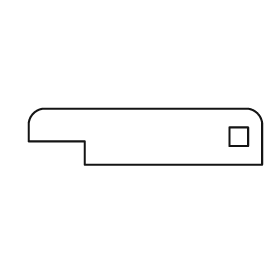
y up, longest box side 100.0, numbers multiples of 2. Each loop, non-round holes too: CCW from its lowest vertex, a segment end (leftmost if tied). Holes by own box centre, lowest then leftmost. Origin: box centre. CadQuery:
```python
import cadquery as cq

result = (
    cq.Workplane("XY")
    .moveTo(-26.0, -12.0)
    .lineTo(50.0, -12.0)
    .lineTo(50.0, 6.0)
    .threePointArc((48.0, 10.0), (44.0, 12.0))
    .lineTo(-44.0, 12.0)
    .threePointArc((-48.0, 10.0), (-50.0, 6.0))
    .lineTo(-50.0, -2.0)
    .lineTo(-26.0, -2.0)
    .close()
    .moveTo(36.0, -4.0)
    .lineTo(44.0, -4.0)
    .lineTo(44.0, 4.0)
    .lineTo(36.0, 4.0)
    .close()
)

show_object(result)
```